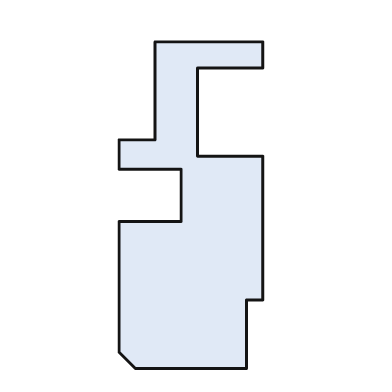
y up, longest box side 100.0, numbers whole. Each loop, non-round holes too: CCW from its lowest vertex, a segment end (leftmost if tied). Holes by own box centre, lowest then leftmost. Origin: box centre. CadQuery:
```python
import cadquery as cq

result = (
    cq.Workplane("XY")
    .moveTo(-17.0, -50.0)
    .lineTo(17.0, -50.0)
    .lineTo(17.0, -29.0)
    .lineTo(22.0, -29.0)
    .lineTo(22.0, 15.0)
    .lineTo(2.0, 15.0)
    .lineTo(2.0, 42.0)
    .lineTo(22.0, 42.0)
    .lineTo(22.0, 50.0)
    .lineTo(-11.0, 50.0)
    .lineTo(-11.0, 20.0)
    .lineTo(-22.0, 20.0)
    .lineTo(-22.0, 11.0)
    .lineTo(-3.0, 11.0)
    .lineTo(-3.0, -5.0)
    .lineTo(-22.0, -5.0)
    .lineTo(-22.0, -45.0)
    .close()
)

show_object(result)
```